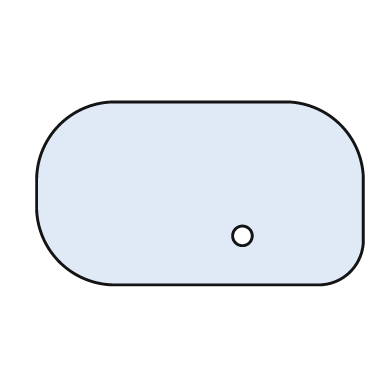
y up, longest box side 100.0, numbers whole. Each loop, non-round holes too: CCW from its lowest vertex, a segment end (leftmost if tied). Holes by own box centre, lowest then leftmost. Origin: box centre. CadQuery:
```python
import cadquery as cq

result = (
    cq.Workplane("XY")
    .moveTo(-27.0, -28.0)
    .lineTo(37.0, -28.0)
    .threePointArc((46.0, -24.0), (50.0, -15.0))
    .lineTo(50.0, 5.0)
    .threePointArc((43.0, 21.0), (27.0, 28.0))
    .lineTo(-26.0, 28.0)
    .threePointArc((-43.0, 21.0), (-50.0, 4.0))
    .lineTo(-50.0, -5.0)
    .threePointArc((-43.0, -21.0), (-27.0, -28.0))
    .close()
    .moveTo(13.0, -13.0)
    .circle(3.0)
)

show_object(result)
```